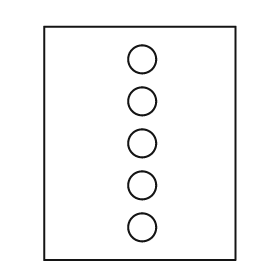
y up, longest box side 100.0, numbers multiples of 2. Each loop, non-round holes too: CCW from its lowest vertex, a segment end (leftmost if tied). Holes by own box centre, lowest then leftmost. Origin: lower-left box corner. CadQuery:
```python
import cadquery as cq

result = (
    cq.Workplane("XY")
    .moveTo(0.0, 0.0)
    .lineTo(82.0, 0.0)
    .lineTo(82.0, 100.0)
    .lineTo(0.0, 100.0)
    .close()
    .moveTo(42.0, 14.0)
    .circle(6.0)
    .moveTo(42.0, 32.0)
    .circle(6.0)
    .moveTo(42.0, 50.0)
    .circle(6.0)
    .moveTo(42.0, 68.0)
    .circle(6.0)
    .moveTo(42.0, 86.0)
    .circle(6.0)
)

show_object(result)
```